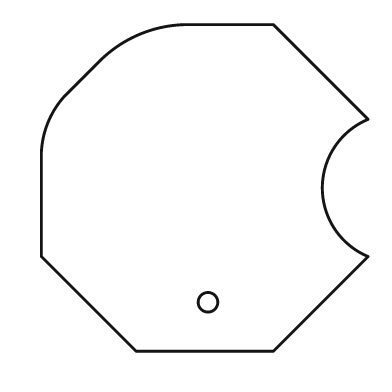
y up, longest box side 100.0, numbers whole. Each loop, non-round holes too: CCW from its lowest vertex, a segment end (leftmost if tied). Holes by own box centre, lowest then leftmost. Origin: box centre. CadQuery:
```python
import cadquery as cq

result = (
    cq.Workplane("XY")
    .moveTo(-21.0, -50.0)
    .lineTo(21.0, -50.0)
    .lineTo(50.0, -21.0)
    .threePointArc((36.0, 0.0), (50.0, 21.0))
    .lineTo(21.0, 50.0)
    .lineTo(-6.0, 50.0)
    .threePointArc((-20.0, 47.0), (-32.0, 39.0))
    .lineTo(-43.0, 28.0)
    .threePointArc((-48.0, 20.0), (-50.0, 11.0))
    .lineTo(-50.0, -21.0)
    .close()
    .moveTo(1.0, -35.0)
    .circle(3.0)
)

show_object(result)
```